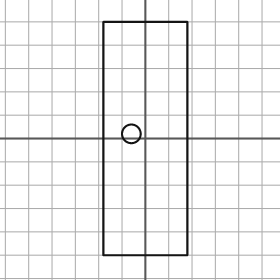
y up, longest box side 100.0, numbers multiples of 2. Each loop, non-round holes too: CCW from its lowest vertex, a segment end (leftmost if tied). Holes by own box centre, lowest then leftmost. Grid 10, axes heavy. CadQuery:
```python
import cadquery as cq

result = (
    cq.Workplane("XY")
    .moveTo(-18.0, -50.0)
    .lineTo(18.0, -50.0)
    .lineTo(18.0, 50.0)
    .lineTo(-18.0, 50.0)
    .close()
    .moveTo(-6.0, 2.0)
    .circle(4.0)
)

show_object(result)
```